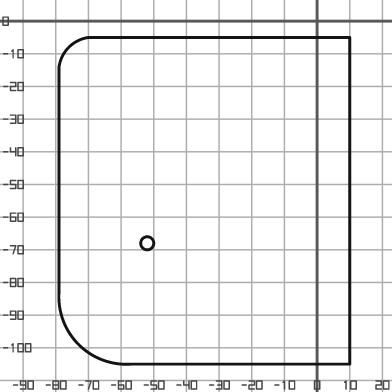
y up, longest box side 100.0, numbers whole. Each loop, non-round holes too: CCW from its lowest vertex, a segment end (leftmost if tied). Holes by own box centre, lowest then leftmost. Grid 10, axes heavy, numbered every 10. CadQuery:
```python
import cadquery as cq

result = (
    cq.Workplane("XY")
    .moveTo(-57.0, -105.0)
    .lineTo(10.0, -105.0)
    .lineTo(10.0, -5.0)
    .lineTo(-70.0, -5.0)
    .threePointArc((-76.0, -8.0), (-79.0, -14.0))
    .lineTo(-79.0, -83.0)
    .threePointArc((-73.0, -99.0), (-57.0, -105.0))
    .close()
    .moveTo(-52.0, -68.0)
    .circle(2.0)
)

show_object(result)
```